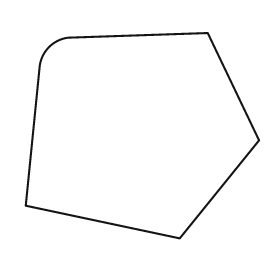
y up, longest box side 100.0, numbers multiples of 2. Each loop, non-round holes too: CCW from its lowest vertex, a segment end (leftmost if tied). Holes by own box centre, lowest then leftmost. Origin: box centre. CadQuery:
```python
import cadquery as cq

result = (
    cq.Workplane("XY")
    .moveTo(16.0, -44.0)
    .lineTo(50.0, -2.0)
    .lineTo(28.0, 44.0)
    .lineTo(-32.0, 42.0)
    .threePointArc((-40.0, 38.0), (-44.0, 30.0))
    .lineTo(-50.0, -30.0)
    .close()
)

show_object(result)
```